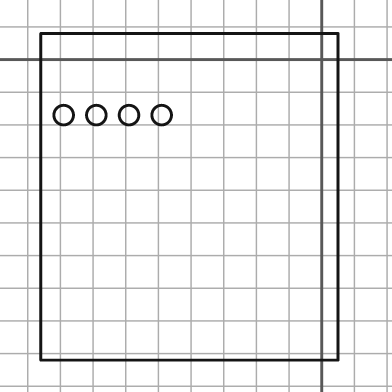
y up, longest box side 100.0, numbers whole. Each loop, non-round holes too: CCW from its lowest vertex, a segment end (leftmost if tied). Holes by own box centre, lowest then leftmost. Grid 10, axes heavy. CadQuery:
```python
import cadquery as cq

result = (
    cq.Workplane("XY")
    .moveTo(-86.0, -92.0)
    .lineTo(5.0, -92.0)
    .lineTo(5.0, 8.0)
    .lineTo(-86.0, 8.0)
    .close()
    .moveTo(-79.0, -17.0)
    .circle(3.0)
    .moveTo(-69.0, -17.0)
    .circle(3.0)
    .moveTo(-59.0, -17.0)
    .circle(3.0)
    .moveTo(-49.0, -17.0)
    .circle(3.0)
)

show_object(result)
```